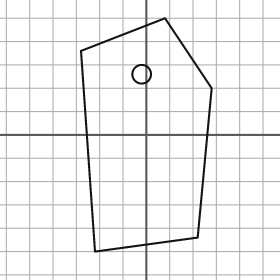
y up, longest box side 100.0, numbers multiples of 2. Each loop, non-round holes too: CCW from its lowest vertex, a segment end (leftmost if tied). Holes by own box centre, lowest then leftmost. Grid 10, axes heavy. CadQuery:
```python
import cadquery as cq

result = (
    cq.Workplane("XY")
    .moveTo(-22.0, -50.0)
    .lineTo(22.0, -44.0)
    .lineTo(28.0, 20.0)
    .lineTo(8.0, 50.0)
    .lineTo(-28.0, 36.0)
    .close()
    .moveTo(-2.0, 26.0)
    .circle(4.0)
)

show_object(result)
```